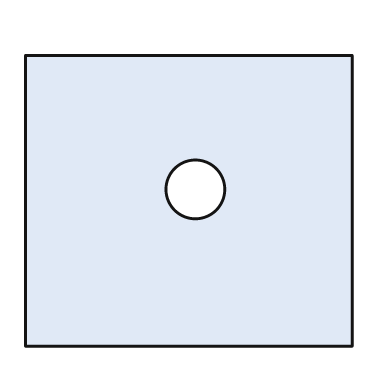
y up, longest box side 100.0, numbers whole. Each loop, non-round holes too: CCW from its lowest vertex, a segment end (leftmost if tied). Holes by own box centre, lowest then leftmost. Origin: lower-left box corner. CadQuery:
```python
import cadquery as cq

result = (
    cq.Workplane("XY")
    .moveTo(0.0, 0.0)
    .lineTo(100.0, 0.0)
    .lineTo(100.0, 89.0)
    .lineTo(0.0, 89.0)
    .close()
    .moveTo(52.0, 48.0)
    .circle(9.0)
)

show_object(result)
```